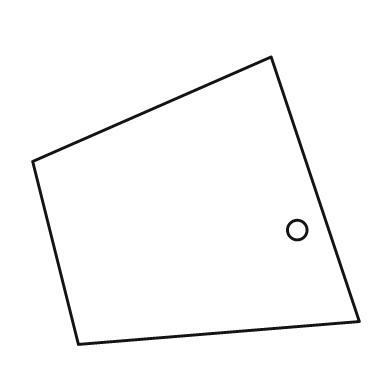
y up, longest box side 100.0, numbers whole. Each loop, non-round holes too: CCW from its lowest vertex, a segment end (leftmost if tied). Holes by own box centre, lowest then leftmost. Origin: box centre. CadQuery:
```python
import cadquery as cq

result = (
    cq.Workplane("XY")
    .moveTo(-36.0, -44.0)
    .lineTo(50.0, -37.0)
    .lineTo(23.0, 44.0)
    .lineTo(-50.0, 12.0)
    .close()
    .moveTo(31.0, -9.0)
    .circle(3.0)
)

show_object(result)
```